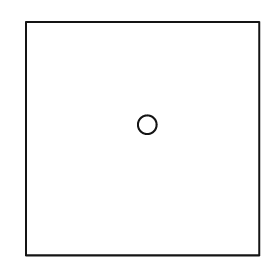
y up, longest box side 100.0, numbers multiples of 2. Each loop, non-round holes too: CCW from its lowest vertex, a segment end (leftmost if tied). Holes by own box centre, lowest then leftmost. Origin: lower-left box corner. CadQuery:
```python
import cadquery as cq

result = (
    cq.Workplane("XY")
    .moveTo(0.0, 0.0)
    .lineTo(100.0, 0.0)
    .lineTo(100.0, 100.0)
    .lineTo(0.0, 100.0)
    .close()
    .moveTo(52.0, 56.0)
    .circle(4.0)
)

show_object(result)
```